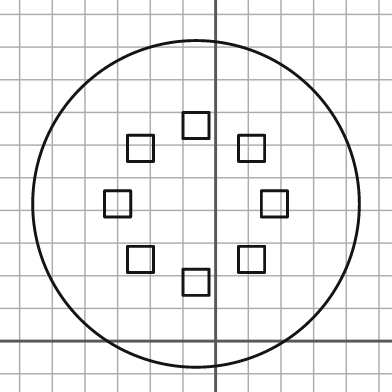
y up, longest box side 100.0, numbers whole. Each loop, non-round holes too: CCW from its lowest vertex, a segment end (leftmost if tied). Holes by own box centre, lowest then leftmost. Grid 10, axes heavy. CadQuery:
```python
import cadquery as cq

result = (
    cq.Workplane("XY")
    .moveTo(-6.0, 42.0)
    .circle(50.0)
    .moveTo(-10.0, 14.0)
    .lineTo(-2.0, 14.0)
    .lineTo(-2.0, 22.0)
    .lineTo(-10.0, 22.0)
    .close()
    .moveTo(-27.0, 21.0)
    .lineTo(-19.0, 21.0)
    .lineTo(-19.0, 29.0)
    .lineTo(-27.0, 29.0)
    .close()
    .moveTo(7.0, 21.0)
    .lineTo(15.0, 21.0)
    .lineTo(15.0, 29.0)
    .lineTo(7.0, 29.0)
    .close()
    .moveTo(-34.0, 38.0)
    .lineTo(-26.0, 38.0)
    .lineTo(-26.0, 46.0)
    .lineTo(-34.0, 46.0)
    .close()
    .moveTo(14.0, 38.0)
    .lineTo(22.0, 38.0)
    .lineTo(22.0, 46.0)
    .lineTo(14.0, 46.0)
    .close()
    .moveTo(-27.0, 55.0)
    .lineTo(-19.0, 55.0)
    .lineTo(-19.0, 63.0)
    .lineTo(-27.0, 63.0)
    .close()
    .moveTo(7.0, 55.0)
    .lineTo(15.0, 55.0)
    .lineTo(15.0, 63.0)
    .lineTo(7.0, 63.0)
    .close()
    .moveTo(-10.0, 62.0)
    .lineTo(-2.0, 62.0)
    .lineTo(-2.0, 70.0)
    .lineTo(-10.0, 70.0)
    .close()
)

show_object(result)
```